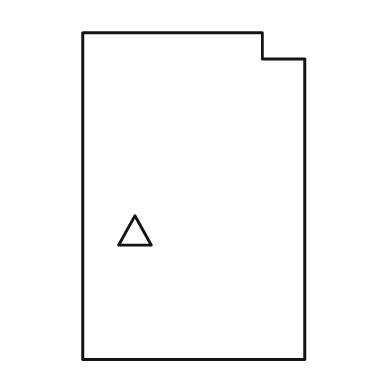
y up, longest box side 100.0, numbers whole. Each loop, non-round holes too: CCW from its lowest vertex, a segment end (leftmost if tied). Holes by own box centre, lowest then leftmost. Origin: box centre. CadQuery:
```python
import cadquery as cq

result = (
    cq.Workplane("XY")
    .moveTo(-34.0, -50.0)
    .lineTo(34.0, -50.0)
    .lineTo(34.0, 42.0)
    .lineTo(21.0, 42.0)
    .lineTo(21.0, 50.0)
    .lineTo(-34.0, 50.0)
    .close()
    .moveTo(-23.0, -15.0)
    .lineTo(-13.0, -15.0)
    .lineTo(-18.0, -6.0)
    .close()
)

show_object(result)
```